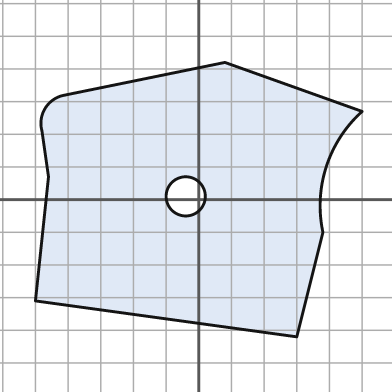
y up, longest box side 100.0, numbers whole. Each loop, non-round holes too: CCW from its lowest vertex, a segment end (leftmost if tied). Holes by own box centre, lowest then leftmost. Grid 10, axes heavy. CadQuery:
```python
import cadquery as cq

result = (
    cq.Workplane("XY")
    .moveTo(30.0, -42.0)
    .lineTo(38.0, -10.0)
    .threePointArc((39.0, 10.0), (50.0, 27.0))
    .lineTo(8.0, 42.0)
    .lineTo(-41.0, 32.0)
    .threePointArc((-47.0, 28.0), (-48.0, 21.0))
    .lineTo(-46.0, 7.0)
    .lineTo(-50.0, -31.0)
    .close()
    .moveTo(-4.0, 1.0)
    .circle(6.0)
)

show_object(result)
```